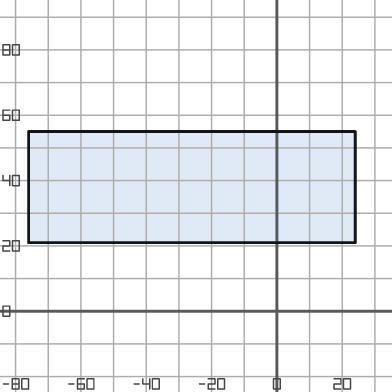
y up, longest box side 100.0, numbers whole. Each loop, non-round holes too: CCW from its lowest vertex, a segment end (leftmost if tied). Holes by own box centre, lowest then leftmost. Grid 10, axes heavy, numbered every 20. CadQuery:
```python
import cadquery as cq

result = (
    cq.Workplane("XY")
    .moveTo(-76.0, 21.0)
    .lineTo(24.0, 21.0)
    .lineTo(24.0, 55.0)
    .lineTo(-76.0, 55.0)
    .close()
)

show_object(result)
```